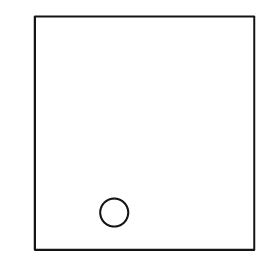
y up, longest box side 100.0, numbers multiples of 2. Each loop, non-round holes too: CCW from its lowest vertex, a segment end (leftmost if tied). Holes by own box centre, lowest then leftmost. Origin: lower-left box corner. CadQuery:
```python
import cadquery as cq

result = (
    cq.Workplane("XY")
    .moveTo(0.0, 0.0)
    .lineTo(94.0, 0.0)
    .lineTo(94.0, 100.0)
    .lineTo(0.0, 100.0)
    .close()
    .moveTo(34.0, 16.0)
    .circle(6.0)
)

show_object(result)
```